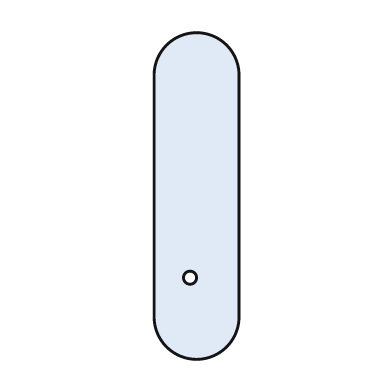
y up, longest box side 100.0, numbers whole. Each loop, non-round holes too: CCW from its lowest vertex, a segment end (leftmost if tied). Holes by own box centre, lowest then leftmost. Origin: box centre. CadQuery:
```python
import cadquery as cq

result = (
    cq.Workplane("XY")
    .moveTo(-13.0, -37.0)
    .threePointArc((0.0, -50.0), (13.0, -37.0))
    .lineTo(13.0, 37.0)
    .threePointArc((0.0, 50.0), (-13.0, 37.0))
    .close()
    .moveTo(-2.0, -25.0)
    .circle(2.0)
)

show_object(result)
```